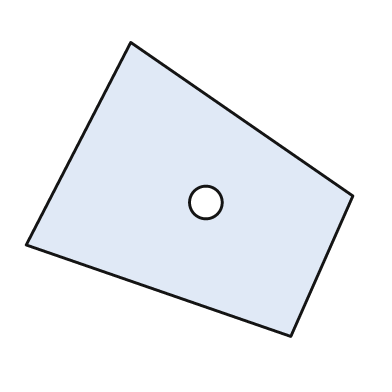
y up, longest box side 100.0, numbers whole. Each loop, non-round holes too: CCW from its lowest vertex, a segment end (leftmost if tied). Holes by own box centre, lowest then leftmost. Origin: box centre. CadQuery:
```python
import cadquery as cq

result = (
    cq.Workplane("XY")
    .moveTo(31.0, -45.0)
    .lineTo(50.0, -2.0)
    .lineTo(-18.0, 45.0)
    .lineTo(-50.0, -17.0)
    .close()
    .moveTo(5.0, -4.0)
    .circle(5.0)
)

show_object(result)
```